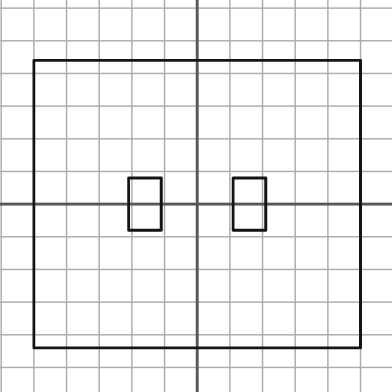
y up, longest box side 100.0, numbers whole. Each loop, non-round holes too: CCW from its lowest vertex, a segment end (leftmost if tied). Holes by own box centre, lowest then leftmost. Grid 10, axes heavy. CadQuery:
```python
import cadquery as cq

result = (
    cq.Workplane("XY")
    .moveTo(-50.0, -44.0)
    .lineTo(50.0, -44.0)
    .lineTo(50.0, 44.0)
    .lineTo(-50.0, 44.0)
    .close()
    .moveTo(-21.0, -8.0)
    .lineTo(-11.0, -8.0)
    .lineTo(-11.0, 8.0)
    .lineTo(-21.0, 8.0)
    .close()
    .moveTo(11.0, -8.0)
    .lineTo(21.0, -8.0)
    .lineTo(21.0, 8.0)
    .lineTo(11.0, 8.0)
    .close()
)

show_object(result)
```